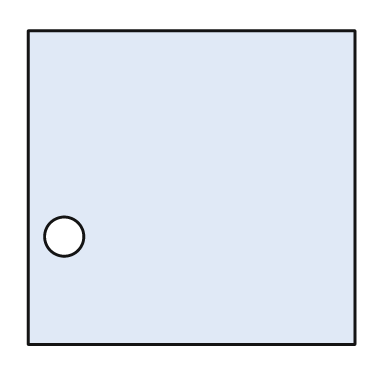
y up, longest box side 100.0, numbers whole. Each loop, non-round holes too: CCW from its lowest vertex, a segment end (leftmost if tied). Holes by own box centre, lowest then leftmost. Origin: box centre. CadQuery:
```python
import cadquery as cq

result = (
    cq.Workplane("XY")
    .moveTo(-50.0, -48.0)
    .lineTo(50.0, -48.0)
    .lineTo(50.0, 48.0)
    .lineTo(-50.0, 48.0)
    .close()
    .moveTo(-39.0, -15.0)
    .circle(6.0)
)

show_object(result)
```